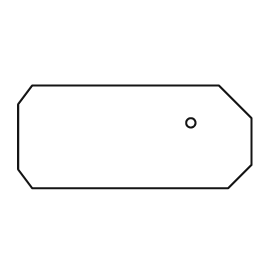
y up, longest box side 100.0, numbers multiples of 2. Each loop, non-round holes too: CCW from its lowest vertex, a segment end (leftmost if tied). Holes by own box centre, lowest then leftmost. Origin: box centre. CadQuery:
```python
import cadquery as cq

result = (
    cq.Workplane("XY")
    .moveTo(-44.0, -22.0)
    .lineTo(40.0, -22.0)
    .lineTo(50.0, -12.0)
    .lineTo(50.0, 8.0)
    .lineTo(36.0, 22.0)
    .lineTo(-44.0, 22.0)
    .lineTo(-50.0, 14.0)
    .lineTo(-50.0, -14.0)
    .close()
    .moveTo(24.0, 6.0)
    .circle(2.0)
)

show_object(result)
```